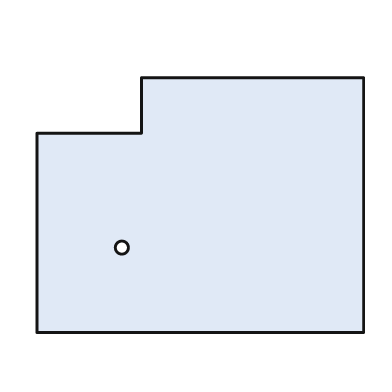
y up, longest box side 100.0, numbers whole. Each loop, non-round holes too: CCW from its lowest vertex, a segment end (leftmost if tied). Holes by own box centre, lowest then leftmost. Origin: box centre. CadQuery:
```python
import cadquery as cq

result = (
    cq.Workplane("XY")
    .moveTo(-50.0, -39.0)
    .lineTo(50.0, -39.0)
    .lineTo(50.0, 39.0)
    .lineTo(-18.0, 39.0)
    .lineTo(-18.0, 22.0)
    .lineTo(-50.0, 22.0)
    .close()
    .moveTo(-24.0, -13.0)
    .circle(2.0)
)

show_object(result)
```